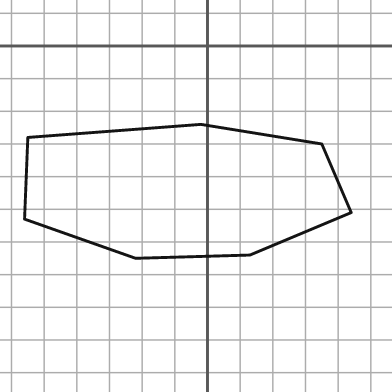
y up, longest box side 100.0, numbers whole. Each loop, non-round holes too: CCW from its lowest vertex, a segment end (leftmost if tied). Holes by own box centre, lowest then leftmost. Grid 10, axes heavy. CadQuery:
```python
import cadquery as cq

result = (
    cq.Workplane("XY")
    .moveTo(-22.0, -65.0)
    .lineTo(13.0, -64.0)
    .lineTo(44.0, -51.0)
    .lineTo(35.0, -30.0)
    .lineTo(-2.0, -24.0)
    .lineTo(-55.0, -28.0)
    .lineTo(-56.0, -53.0)
    .close()
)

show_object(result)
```